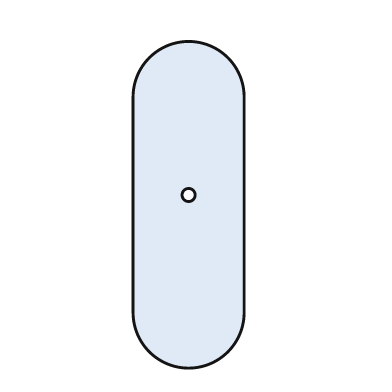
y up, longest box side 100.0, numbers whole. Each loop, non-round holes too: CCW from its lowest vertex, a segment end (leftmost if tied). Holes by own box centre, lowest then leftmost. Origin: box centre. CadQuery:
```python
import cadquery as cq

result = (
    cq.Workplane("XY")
    .moveTo(-17.0, -33.0)
    .threePointArc((0.0, -50.0), (17.0, -33.0))
    .lineTo(17.0, 33.0)
    .threePointArc((0.0, 50.0), (-17.0, 33.0))
    .close()
    .moveTo(0.0, 3.0)
    .circle(2.0)
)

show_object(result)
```